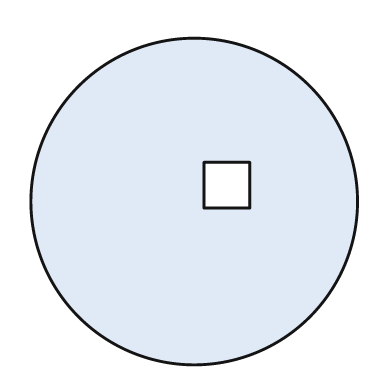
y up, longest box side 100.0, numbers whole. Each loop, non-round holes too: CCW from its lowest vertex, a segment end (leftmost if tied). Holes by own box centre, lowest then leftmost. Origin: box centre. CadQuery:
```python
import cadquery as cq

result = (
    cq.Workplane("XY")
    .moveTo(0.0, 0.0)
    .circle(50.0)
    .moveTo(3.0, -2.0)
    .lineTo(17.0, -2.0)
    .lineTo(17.0, 12.0)
    .lineTo(3.0, 12.0)
    .close()
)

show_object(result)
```